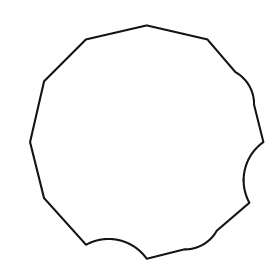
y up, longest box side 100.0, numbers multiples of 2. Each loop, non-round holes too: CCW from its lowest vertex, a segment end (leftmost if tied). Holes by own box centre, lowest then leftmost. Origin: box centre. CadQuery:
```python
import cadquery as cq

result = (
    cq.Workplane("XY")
    .moveTo(0.0, -50.0)
    .lineTo(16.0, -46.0)
    .threePointArc((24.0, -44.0), (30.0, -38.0))
    .lineTo(44.0, -26.0)
    .threePointArc((42.0, -12.0), (50.0, 0.0))
    .lineTo(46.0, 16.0)
    .threePointArc((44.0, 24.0), (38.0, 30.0))
    .lineTo(26.0, 44.0)
    .lineTo(0.0, 50.0)
    .lineTo(-26.0, 44.0)
    .lineTo(-44.0, 26.0)
    .lineTo(-50.0, 0.0)
    .lineTo(-44.0, -24.0)
    .lineTo(-26.0, -44.0)
    .threePointArc((-12.0, -42.0), (0.0, -50.0))
    .close()
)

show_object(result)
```